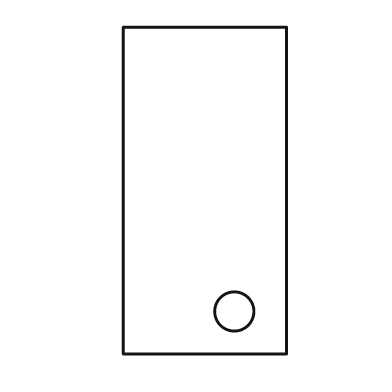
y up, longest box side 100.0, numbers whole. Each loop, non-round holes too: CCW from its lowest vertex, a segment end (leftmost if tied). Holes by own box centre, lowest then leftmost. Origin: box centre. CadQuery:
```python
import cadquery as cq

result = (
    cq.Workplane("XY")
    .moveTo(-25.0, -50.0)
    .lineTo(25.0, -50.0)
    .lineTo(25.0, 50.0)
    .lineTo(-25.0, 50.0)
    .close()
    .moveTo(9.0, -37.0)
    .circle(6.0)
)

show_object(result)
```